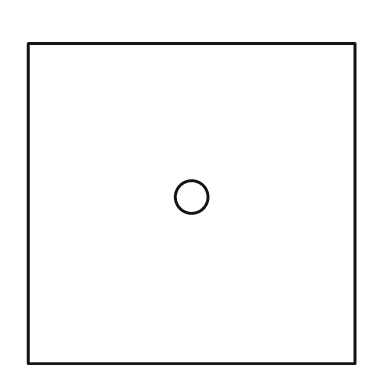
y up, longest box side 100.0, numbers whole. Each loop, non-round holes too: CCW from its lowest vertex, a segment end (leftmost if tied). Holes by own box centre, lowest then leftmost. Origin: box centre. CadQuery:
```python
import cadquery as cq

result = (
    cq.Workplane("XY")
    .moveTo(-50.0, -49.0)
    .lineTo(50.0, -49.0)
    .lineTo(50.0, 49.0)
    .lineTo(-50.0, 49.0)
    .close()
    .moveTo(0.0, 2.0)
    .circle(5.0)
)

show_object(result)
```